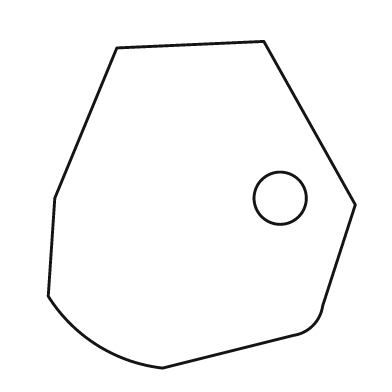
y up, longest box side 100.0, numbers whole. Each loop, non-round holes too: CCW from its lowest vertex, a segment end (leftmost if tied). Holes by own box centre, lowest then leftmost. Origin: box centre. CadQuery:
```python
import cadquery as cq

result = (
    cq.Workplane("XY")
    .moveTo(-12.0, -50.0)
    .lineTo(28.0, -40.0)
    .threePointArc((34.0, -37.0), (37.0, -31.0))
    .lineTo(47.0, 0.0)
    .lineTo(19.0, 50.0)
    .lineTo(-26.0, 48.0)
    .lineTo(-45.0, 2.0)
    .lineTo(-47.0, -28.0)
    .threePointArc((-32.0, -43.0), (-12.0, -50.0))
    .close()
    .moveTo(24.0, 2.0)
    .circle(8.0)
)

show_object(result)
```